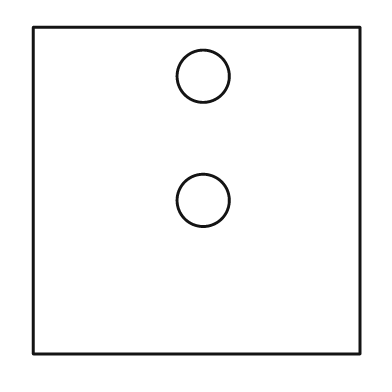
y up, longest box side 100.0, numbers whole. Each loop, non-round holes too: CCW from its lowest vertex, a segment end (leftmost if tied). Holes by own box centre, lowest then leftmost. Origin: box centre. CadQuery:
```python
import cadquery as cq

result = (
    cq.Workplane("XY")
    .moveTo(-50.0, -50.0)
    .lineTo(50.0, -50.0)
    .lineTo(50.0, 50.0)
    .lineTo(-50.0, 50.0)
    .close()
    .moveTo(2.0, -3.0)
    .circle(8.0)
    .moveTo(2.0, 35.0)
    .circle(8.0)
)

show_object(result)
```